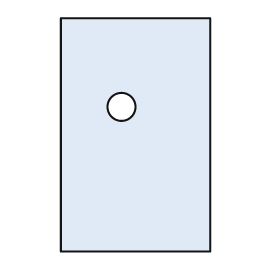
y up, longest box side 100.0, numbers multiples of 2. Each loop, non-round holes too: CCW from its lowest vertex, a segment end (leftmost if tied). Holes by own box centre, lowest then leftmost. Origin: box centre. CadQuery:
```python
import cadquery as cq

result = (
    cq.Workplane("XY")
    .moveTo(-32.0, -50.0)
    .lineTo(32.0, -50.0)
    .lineTo(32.0, 50.0)
    .lineTo(-32.0, 50.0)
    .close()
    .moveTo(-6.0, 12.0)
    .circle(6.0)
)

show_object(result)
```